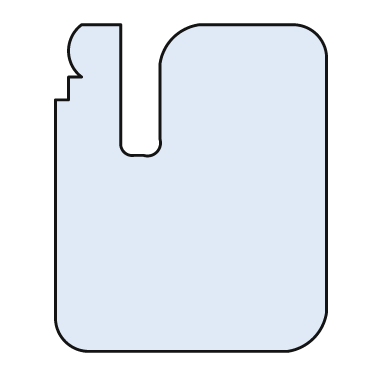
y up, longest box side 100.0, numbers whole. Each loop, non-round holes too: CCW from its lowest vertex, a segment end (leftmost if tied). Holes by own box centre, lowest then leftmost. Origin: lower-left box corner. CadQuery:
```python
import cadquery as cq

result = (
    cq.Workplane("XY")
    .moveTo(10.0, 0.0)
    .lineTo(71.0, 0.0)
    .threePointArc((79.0, 4.0), (83.0, 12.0))
    .lineTo(83.0, 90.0)
    .threePointArc((80.0, 97.0), (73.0, 100.0))
    .lineTo(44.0, 100.0)
    .threePointArc((36.0, 96.0), (32.0, 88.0))
    .lineTo(32.0, 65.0)
    .threePointArc((31.0, 61.0), (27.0, 60.0))
    .lineTo(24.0, 60.0)
    .threePointArc((21.0, 61.0), (20.0, 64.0))
    .lineTo(20.0, 100.0)
    .lineTo(8.0, 100.0)
    .threePointArc((4.0, 92.0), (8.0, 84.0))
    .lineTo(4.0, 84.0)
    .lineTo(4.0, 77.0)
    .lineTo(0.0, 77.0)
    .lineTo(0.0, 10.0)
    .threePointArc((3.0, 3.0), (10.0, 0.0))
    .close()
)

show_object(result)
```